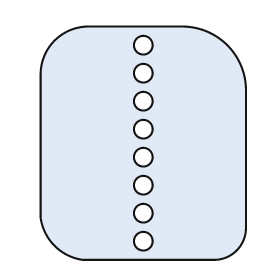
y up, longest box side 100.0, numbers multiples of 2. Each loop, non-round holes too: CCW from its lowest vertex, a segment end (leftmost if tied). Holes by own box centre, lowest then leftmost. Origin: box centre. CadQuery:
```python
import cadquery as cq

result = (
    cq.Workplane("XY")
    .moveTo(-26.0, -50.0)
    .lineTo(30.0, -50.0)
    .threePointArc((40.0, -46.0), (44.0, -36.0))
    .lineTo(44.0, 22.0)
    .threePointArc((36.0, 42.0), (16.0, 50.0))
    .lineTo(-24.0, 50.0)
    .threePointArc((-38.0, 44.0), (-44.0, 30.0))
    .lineTo(-44.0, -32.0)
    .threePointArc((-38.0, -44.0), (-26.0, -50.0))
    .close()
    .moveTo(0.0, -42.0)
    .circle(4.0)
    .moveTo(0.0, -30.0)
    .circle(4.0)
    .moveTo(0.0, -18.0)
    .circle(4.0)
    .moveTo(0.0, -6.0)
    .circle(4.0)
    .moveTo(0.0, 6.0)
    .circle(4.0)
    .moveTo(0.0, 18.0)
    .circle(4.0)
    .moveTo(0.0, 30.0)
    .circle(4.0)
    .moveTo(0.0, 42.0)
    .circle(4.0)
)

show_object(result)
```